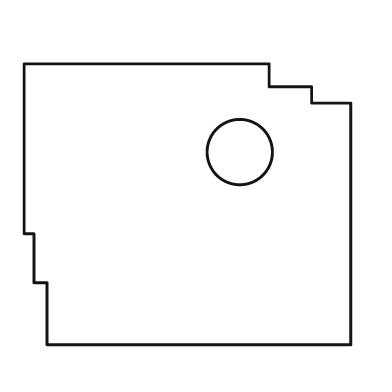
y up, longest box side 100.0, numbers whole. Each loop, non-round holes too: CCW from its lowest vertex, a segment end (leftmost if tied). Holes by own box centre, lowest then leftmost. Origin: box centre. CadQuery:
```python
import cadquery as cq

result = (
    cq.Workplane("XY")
    .moveTo(-43.0, -43.0)
    .lineTo(50.0, -43.0)
    .lineTo(50.0, 31.0)
    .lineTo(38.0, 31.0)
    .lineTo(38.0, 36.0)
    .lineTo(25.0, 36.0)
    .lineTo(25.0, 43.0)
    .lineTo(-50.0, 43.0)
    .lineTo(-50.0, -9.0)
    .lineTo(-47.0, -9.0)
    .lineTo(-47.0, -24.0)
    .lineTo(-43.0, -24.0)
    .close()
    .moveTo(16.0, 16.0)
    .circle(10.0)
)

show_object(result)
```